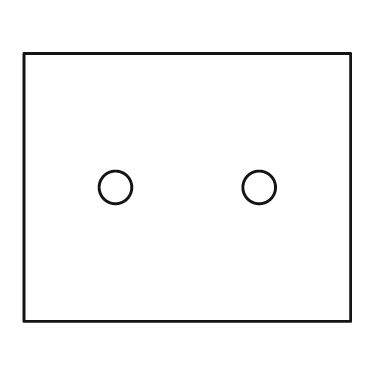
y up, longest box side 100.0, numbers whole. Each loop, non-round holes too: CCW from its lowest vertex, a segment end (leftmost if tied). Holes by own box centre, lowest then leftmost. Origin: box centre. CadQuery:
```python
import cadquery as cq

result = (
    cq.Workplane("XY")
    .moveTo(-50.0, -41.0)
    .lineTo(50.0, -41.0)
    .lineTo(50.0, 41.0)
    .lineTo(-50.0, 41.0)
    .close()
    .moveTo(-22.0, 0.0)
    .circle(5.0)
    .moveTo(22.0, 0.0)
    .circle(5.0)
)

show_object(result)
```